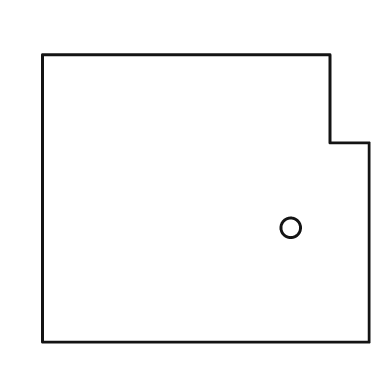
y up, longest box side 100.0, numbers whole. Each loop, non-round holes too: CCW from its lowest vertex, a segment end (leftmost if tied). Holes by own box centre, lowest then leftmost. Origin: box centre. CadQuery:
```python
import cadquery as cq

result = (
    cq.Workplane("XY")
    .moveTo(-50.0, -44.0)
    .lineTo(50.0, -44.0)
    .lineTo(50.0, 17.0)
    .lineTo(38.0, 17.0)
    .lineTo(38.0, 44.0)
    .lineTo(-50.0, 44.0)
    .close()
    .moveTo(26.0, -9.0)
    .circle(3.0)
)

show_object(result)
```